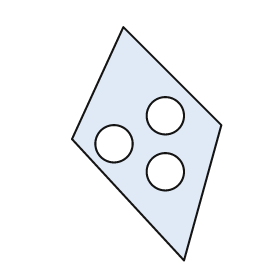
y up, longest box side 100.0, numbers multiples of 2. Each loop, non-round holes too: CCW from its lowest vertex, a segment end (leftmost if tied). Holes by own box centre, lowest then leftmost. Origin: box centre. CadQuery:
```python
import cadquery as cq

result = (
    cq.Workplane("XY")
    .moveTo(16.0, -50.0)
    .lineTo(32.0, 8.0)
    .lineTo(-10.0, 50.0)
    .lineTo(-32.0, 2.0)
    .close()
    .moveTo(8.0, -12.0)
    .circle(8.0)
    .moveTo(-14.0, 0.0)
    .circle(8.0)
    .moveTo(8.0, 12.0)
    .circle(8.0)
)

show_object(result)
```